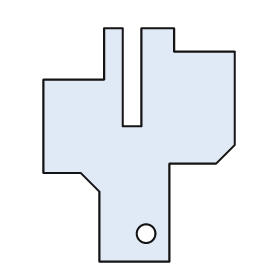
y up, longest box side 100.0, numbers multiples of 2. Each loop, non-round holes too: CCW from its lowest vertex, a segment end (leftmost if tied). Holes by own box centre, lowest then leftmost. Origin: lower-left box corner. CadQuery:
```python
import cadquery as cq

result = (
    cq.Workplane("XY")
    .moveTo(24.0, 0.0)
    .lineTo(54.0, 0.0)
    .lineTo(54.0, 42.0)
    .lineTo(74.0, 42.0)
    .lineTo(82.0, 50.0)
    .lineTo(82.0, 90.0)
    .lineTo(56.0, 90.0)
    .lineTo(56.0, 100.0)
    .lineTo(42.0, 100.0)
    .lineTo(42.0, 58.0)
    .lineTo(34.0, 58.0)
    .lineTo(34.0, 100.0)
    .lineTo(26.0, 100.0)
    .lineTo(26.0, 78.0)
    .lineTo(0.0, 78.0)
    .lineTo(0.0, 38.0)
    .lineTo(16.0, 38.0)
    .lineTo(24.0, 30.0)
    .close()
    .moveTo(44.0, 12.0)
    .circle(4.0)
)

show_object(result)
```